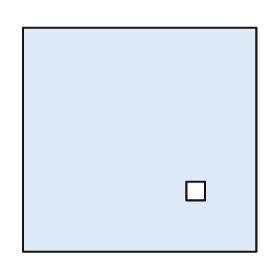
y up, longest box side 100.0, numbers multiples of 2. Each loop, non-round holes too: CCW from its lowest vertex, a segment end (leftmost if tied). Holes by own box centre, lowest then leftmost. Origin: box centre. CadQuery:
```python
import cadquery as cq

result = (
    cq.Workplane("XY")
    .moveTo(-50.0, -48.0)
    .lineTo(50.0, -48.0)
    .lineTo(50.0, 48.0)
    .lineTo(-50.0, 48.0)
    .close()
    .moveTo(20.0, -26.0)
    .lineTo(28.0, -26.0)
    .lineTo(28.0, -18.0)
    .lineTo(20.0, -18.0)
    .close()
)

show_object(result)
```